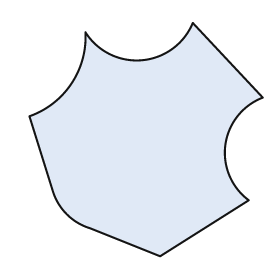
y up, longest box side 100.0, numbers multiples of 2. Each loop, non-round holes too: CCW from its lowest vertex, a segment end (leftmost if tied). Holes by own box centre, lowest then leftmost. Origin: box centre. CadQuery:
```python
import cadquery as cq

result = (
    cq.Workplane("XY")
    .moveTo(6.0, -50.0)
    .lineTo(44.0, -26.0)
    .threePointArc((34.0, -2.0), (50.0, 18.0))
    .lineTo(20.0, 50.0)
    .threePointArc((-2.0, 34.0), (-26.0, 46.0))
    .threePointArc((-32.0, 24.0), (-50.0, 10.0))
    .lineTo(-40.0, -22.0)
    .threePointArc((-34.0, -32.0), (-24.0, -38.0))
    .close()
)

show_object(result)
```